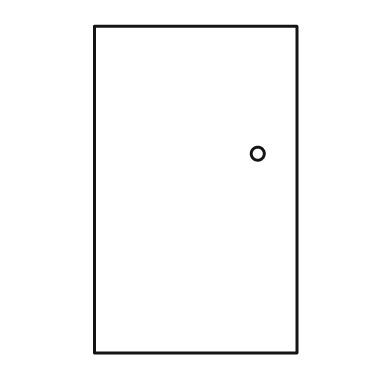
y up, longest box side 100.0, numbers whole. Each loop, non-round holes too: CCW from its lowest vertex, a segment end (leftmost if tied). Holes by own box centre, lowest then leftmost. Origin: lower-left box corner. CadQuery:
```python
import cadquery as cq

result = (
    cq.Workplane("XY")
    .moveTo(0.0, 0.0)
    .lineTo(62.0, 0.0)
    .lineTo(62.0, 100.0)
    .lineTo(0.0, 100.0)
    .close()
    .moveTo(50.0, 61.0)
    .circle(2.0)
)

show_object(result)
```